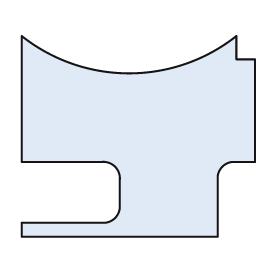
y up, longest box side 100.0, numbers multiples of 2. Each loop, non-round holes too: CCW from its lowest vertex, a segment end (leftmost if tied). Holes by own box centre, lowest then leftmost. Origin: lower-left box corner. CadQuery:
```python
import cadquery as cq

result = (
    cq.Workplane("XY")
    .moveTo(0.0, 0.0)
    .lineTo(84.0, 0.0)
    .lineTo(84.0, 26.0)
    .threePointArc((86.0, 30.0), (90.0, 32.0))
    .lineTo(100.0, 32.0)
    .lineTo(100.0, 76.0)
    .lineTo(92.0, 76.0)
    .lineTo(92.0, 86.0)
    .threePointArc((46.0, 70.0), (0.0, 86.0))
    .lineTo(0.0, 32.0)
    .lineTo(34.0, 32.0)
    .threePointArc((40.0, 30.0), (42.0, 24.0))
    .lineTo(42.0, 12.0)
    .threePointArc((40.0, 8.0), (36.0, 6.0))
    .lineTo(0.0, 6.0)
    .close()
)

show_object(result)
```